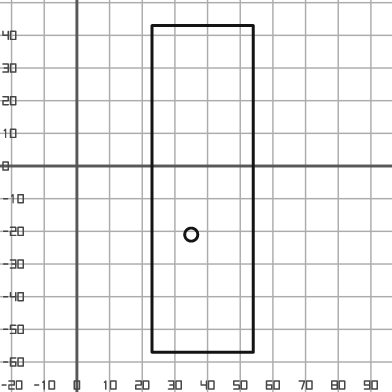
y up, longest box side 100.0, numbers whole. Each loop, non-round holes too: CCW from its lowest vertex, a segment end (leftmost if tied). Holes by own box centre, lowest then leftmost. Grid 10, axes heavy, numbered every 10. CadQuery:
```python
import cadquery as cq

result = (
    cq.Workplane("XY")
    .moveTo(23.0, -57.0)
    .lineTo(54.0, -57.0)
    .lineTo(54.0, 43.0)
    .lineTo(23.0, 43.0)
    .close()
    .moveTo(35.0, -21.0)
    .circle(2.0)
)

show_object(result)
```